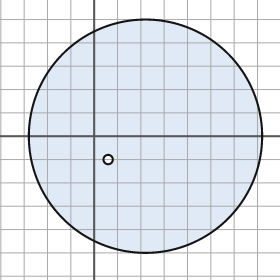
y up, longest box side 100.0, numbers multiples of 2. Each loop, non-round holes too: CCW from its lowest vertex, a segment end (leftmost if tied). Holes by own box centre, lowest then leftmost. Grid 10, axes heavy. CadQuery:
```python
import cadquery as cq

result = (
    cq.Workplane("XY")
    .moveTo(22.0, 0.0)
    .circle(50.0)
    .moveTo(6.0, -10.0)
    .circle(2.0)
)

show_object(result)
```